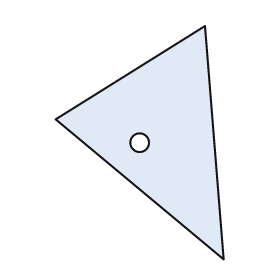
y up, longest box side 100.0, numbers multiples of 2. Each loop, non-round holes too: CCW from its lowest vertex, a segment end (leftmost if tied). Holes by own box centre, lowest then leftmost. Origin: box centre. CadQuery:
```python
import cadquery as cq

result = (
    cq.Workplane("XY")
    .moveTo(36.0, -50.0)
    .lineTo(28.0, 50.0)
    .lineTo(-36.0, 10.0)
    .close()
    .moveTo(0.0, 0.0)
    .circle(4.0)
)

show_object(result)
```